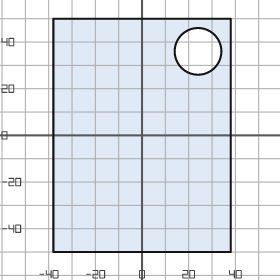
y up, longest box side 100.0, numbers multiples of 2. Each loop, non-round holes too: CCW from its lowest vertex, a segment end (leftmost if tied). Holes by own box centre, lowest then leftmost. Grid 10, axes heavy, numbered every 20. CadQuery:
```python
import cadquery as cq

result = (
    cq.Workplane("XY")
    .moveTo(-38.0, -50.0)
    .lineTo(38.0, -50.0)
    .lineTo(38.0, 50.0)
    .lineTo(-38.0, 50.0)
    .close()
    .moveTo(24.0, 36.0)
    .circle(10.0)
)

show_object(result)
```